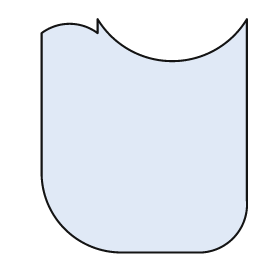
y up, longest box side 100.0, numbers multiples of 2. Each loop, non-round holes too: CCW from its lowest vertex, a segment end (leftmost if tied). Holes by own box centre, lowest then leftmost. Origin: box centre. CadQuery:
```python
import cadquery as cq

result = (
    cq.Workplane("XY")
    .moveTo(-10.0, -50.0)
    .lineTo(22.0, -50.0)
    .threePointArc((38.0, -44.0), (44.0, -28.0))
    .lineTo(44.0, 50.0)
    .threePointArc((12.0, 32.0), (-20.0, 50.0))
    .lineTo(-20.0, 44.0)
    .threePointArc((-32.0, 48.0), (-44.0, 44.0))
    .lineTo(-44.0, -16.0)
    .threePointArc((-34.0, -40.0), (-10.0, -50.0))
    .close()
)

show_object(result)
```